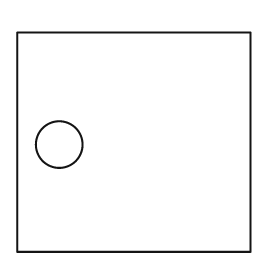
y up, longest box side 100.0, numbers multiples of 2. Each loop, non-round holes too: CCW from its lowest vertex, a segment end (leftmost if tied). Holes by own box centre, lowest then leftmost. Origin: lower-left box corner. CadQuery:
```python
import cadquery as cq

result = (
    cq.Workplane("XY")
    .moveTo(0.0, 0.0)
    .lineTo(100.0, 0.0)
    .lineTo(100.0, 94.0)
    .lineTo(0.0, 94.0)
    .close()
    .moveTo(18.0, 46.0)
    .circle(10.0)
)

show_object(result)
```